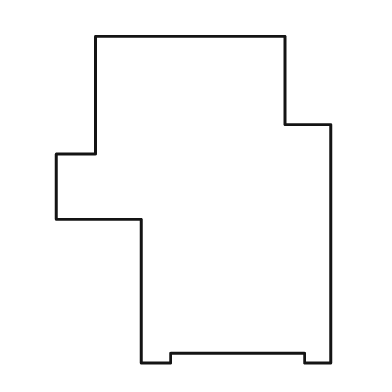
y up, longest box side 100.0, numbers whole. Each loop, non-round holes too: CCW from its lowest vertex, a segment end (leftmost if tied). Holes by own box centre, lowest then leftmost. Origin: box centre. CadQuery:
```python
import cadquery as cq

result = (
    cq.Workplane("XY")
    .moveTo(-16.0, -50.0)
    .lineTo(-7.0, -50.0)
    .lineTo(-7.0, -47.0)
    .lineTo(34.0, -47.0)
    .lineTo(34.0, -50.0)
    .lineTo(42.0, -50.0)
    .lineTo(42.0, 23.0)
    .lineTo(28.0, 23.0)
    .lineTo(28.0, 50.0)
    .lineTo(-30.0, 50.0)
    .lineTo(-30.0, 14.0)
    .lineTo(-42.0, 14.0)
    .lineTo(-42.0, -6.0)
    .lineTo(-16.0, -6.0)
    .close()
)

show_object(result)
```